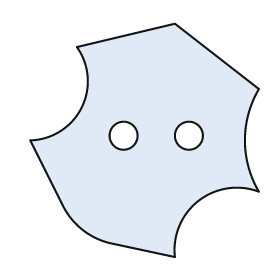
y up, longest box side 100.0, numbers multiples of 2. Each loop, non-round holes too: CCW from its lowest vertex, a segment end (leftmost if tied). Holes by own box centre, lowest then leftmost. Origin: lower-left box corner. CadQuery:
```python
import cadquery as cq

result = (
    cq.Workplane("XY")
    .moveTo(62.0, 0.0)
    .threePointArc((72.0, 24.0), (98.0, 28.0))
    .threePointArc((92.0, 50.0), (98.0, 72.0))
    .lineTo(62.0, 100.0)
    .lineTo(20.0, 90.0)
    .threePointArc((22.0, 64.0), (0.0, 50.0))
    .lineTo(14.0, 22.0)
    .threePointArc((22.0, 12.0), (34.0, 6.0))
    .close()
    .moveTo(40.0, 52.0)
    .circle(6.0)
    .moveTo(68.0, 52.0)
    .circle(6.0)
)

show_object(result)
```